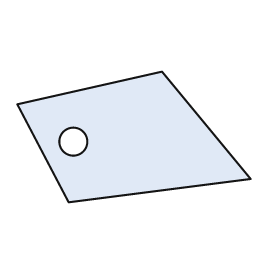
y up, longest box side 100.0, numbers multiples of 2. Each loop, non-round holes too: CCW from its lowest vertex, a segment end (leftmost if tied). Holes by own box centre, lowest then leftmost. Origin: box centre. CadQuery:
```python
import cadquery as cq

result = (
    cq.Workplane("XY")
    .moveTo(-28.0, -28.0)
    .lineTo(50.0, -18.0)
    .lineTo(12.0, 28.0)
    .lineTo(-50.0, 14.0)
    .close()
    .moveTo(-26.0, -2.0)
    .circle(6.0)
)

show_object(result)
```